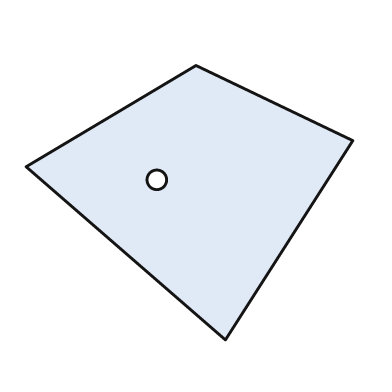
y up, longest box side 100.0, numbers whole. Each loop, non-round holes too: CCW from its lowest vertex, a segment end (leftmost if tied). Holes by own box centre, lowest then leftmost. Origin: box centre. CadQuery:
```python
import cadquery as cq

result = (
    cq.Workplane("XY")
    .moveTo(11.0, -42.0)
    .lineTo(50.0, 19.0)
    .lineTo(2.0, 42.0)
    .lineTo(-50.0, 11.0)
    .close()
    .moveTo(-10.0, 7.0)
    .circle(3.0)
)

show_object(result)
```